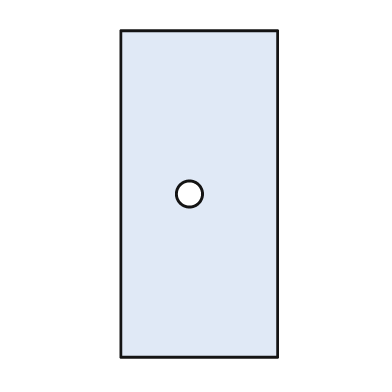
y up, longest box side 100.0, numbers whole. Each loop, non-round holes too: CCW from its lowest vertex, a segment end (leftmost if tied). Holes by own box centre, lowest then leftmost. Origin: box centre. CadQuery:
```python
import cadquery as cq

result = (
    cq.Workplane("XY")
    .moveTo(-24.0, -50.0)
    .lineTo(24.0, -50.0)
    .lineTo(24.0, 50.0)
    .lineTo(-24.0, 50.0)
    .close()
    .moveTo(-3.0, 0.0)
    .circle(4.0)
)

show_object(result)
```